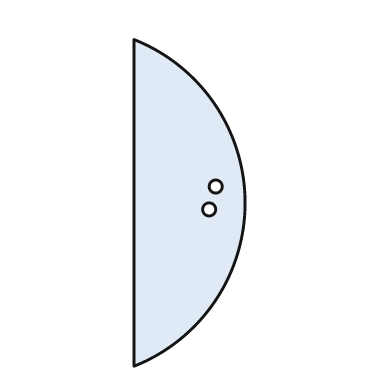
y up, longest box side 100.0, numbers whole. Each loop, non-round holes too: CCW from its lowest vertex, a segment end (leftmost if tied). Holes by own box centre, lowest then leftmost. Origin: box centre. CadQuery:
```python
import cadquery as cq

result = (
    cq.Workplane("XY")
    .moveTo(-17.0, -50.0)
    .threePointArc((17.0, 0.0), (-17.0, 50.0))
    .close()
    .moveTo(6.0, -2.0)
    .circle(2.0)
    .moveTo(8.0, 5.0)
    .circle(2.0)
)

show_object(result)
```